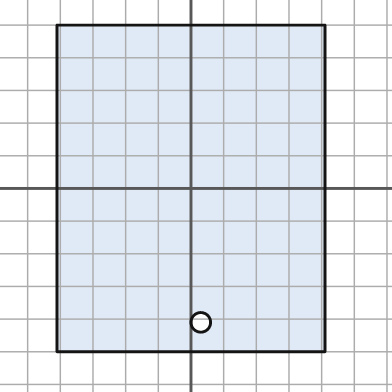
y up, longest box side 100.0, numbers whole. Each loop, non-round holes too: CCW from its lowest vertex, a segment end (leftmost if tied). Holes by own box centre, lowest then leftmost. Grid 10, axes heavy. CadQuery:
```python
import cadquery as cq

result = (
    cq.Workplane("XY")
    .moveTo(-41.0, -50.0)
    .lineTo(41.0, -50.0)
    .lineTo(41.0, 50.0)
    .lineTo(-41.0, 50.0)
    .close()
    .moveTo(3.0, -41.0)
    .circle(3.0)
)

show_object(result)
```